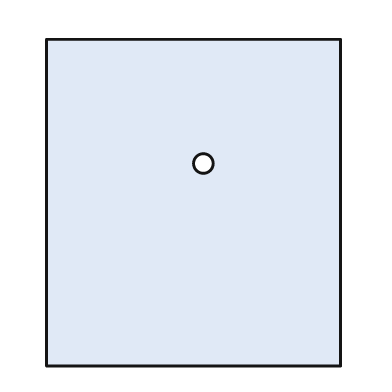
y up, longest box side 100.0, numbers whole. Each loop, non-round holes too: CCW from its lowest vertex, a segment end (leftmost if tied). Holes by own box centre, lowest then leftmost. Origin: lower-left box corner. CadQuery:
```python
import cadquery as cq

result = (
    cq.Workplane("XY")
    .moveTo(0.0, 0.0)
    .lineTo(90.0, 0.0)
    .lineTo(90.0, 100.0)
    .lineTo(0.0, 100.0)
    .close()
    .moveTo(48.0, 62.0)
    .circle(3.0)
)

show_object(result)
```